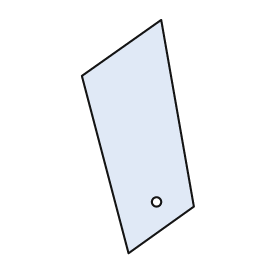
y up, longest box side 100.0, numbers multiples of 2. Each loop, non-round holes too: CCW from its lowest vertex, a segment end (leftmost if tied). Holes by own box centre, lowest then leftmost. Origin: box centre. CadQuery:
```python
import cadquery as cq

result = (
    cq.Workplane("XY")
    .moveTo(-4.0, -50.0)
    .lineTo(24.0, -30.0)
    .lineTo(10.0, 50.0)
    .lineTo(-24.0, 26.0)
    .close()
    .moveTo(8.0, -28.0)
    .circle(2.0)
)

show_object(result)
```